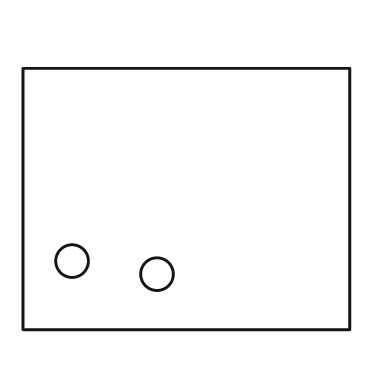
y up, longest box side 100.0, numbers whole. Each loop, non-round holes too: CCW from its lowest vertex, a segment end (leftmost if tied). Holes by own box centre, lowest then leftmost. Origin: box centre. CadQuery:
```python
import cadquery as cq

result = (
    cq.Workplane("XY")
    .moveTo(-50.0, -40.0)
    .lineTo(50.0, -40.0)
    .lineTo(50.0, 40.0)
    .lineTo(-50.0, 40.0)
    .close()
    .moveTo(-9.0, -23.0)
    .circle(5.0)
    .moveTo(-35.0, -19.0)
    .circle(5.0)
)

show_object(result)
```